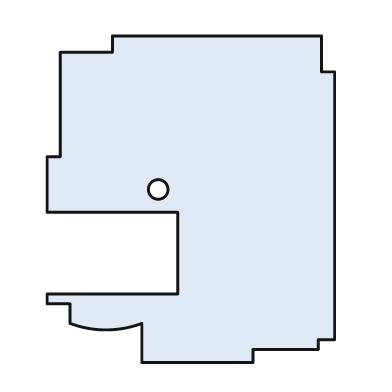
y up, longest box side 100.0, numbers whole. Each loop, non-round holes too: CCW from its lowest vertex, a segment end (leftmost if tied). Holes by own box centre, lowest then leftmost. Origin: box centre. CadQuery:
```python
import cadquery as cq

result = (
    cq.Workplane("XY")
    .moveTo(-15.0, -50.0)
    .lineTo(19.0, -50.0)
    .lineTo(19.0, -46.0)
    .lineTo(39.0, -46.0)
    .lineTo(39.0, -43.0)
    .lineTo(44.0, -43.0)
    .lineTo(44.0, 39.0)
    .lineTo(40.0, 39.0)
    .lineTo(40.0, 50.0)
    .lineTo(-24.0, 50.0)
    .lineTo(-24.0, 45.0)
    .lineTo(-40.0, 45.0)
    .lineTo(-40.0, 13.0)
    .lineTo(-44.0, 13.0)
    .lineTo(-44.0, -4.0)
    .lineTo(-4.0, -4.0)
    .lineTo(-4.0, -29.0)
    .lineTo(-44.0, -29.0)
    .lineTo(-44.0, -32.0)
    .lineTo(-37.0, -32.0)
    .lineTo(-37.0, -38.0)
    .threePointArc((-26.0, -40.0), (-15.0, -38.0))
    .close()
    .moveTo(-10.0, 3.0)
    .circle(3.0)
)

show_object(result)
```